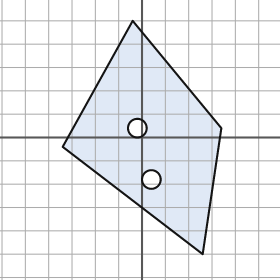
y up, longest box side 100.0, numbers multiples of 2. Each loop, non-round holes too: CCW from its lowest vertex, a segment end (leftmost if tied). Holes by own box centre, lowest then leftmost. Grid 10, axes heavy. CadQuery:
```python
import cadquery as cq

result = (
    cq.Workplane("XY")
    .moveTo(26.0, -50.0)
    .lineTo(34.0, 4.0)
    .lineTo(-4.0, 50.0)
    .lineTo(-34.0, -4.0)
    .close()
    .moveTo(4.0, -18.0)
    .circle(4.0)
    .moveTo(-2.0, 4.0)
    .circle(4.0)
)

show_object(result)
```